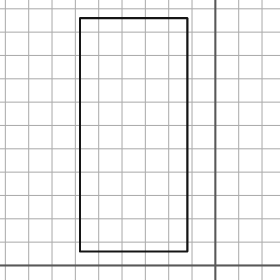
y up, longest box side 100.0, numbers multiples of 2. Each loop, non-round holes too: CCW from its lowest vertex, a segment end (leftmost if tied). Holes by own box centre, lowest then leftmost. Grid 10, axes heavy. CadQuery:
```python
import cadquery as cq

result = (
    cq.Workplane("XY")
    .moveTo(-58.0, 6.0)
    .lineTo(-12.0, 6.0)
    .lineTo(-12.0, 106.0)
    .lineTo(-58.0, 106.0)
    .close()
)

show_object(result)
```